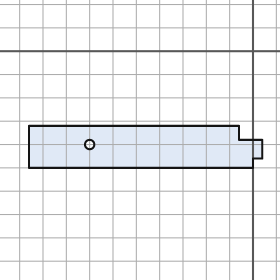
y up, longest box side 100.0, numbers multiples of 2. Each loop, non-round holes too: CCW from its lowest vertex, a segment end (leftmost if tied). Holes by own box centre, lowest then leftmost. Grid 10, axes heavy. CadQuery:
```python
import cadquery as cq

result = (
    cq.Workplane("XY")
    .moveTo(-96.0, -50.0)
    .lineTo(0.0, -50.0)
    .lineTo(0.0, -46.0)
    .lineTo(4.0, -46.0)
    .lineTo(4.0, -38.0)
    .lineTo(-6.0, -38.0)
    .lineTo(-6.0, -32.0)
    .lineTo(-96.0, -32.0)
    .close()
    .moveTo(-70.0, -40.0)
    .circle(2.0)
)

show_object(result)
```